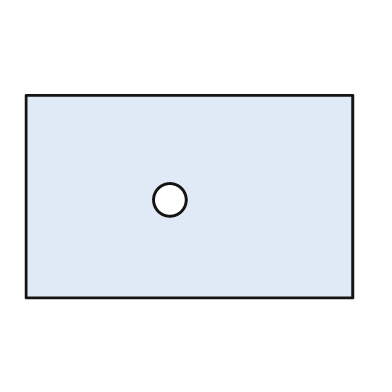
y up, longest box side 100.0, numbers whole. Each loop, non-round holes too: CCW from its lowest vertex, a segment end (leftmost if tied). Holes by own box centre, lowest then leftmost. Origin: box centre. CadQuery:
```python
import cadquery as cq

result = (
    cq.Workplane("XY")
    .moveTo(-50.0, -31.0)
    .lineTo(50.0, -31.0)
    .lineTo(50.0, 31.0)
    .lineTo(-50.0, 31.0)
    .close()
    .moveTo(-6.0, -1.0)
    .circle(5.0)
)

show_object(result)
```